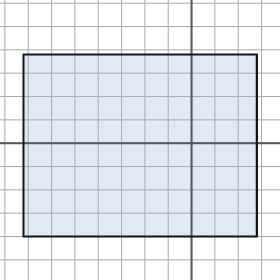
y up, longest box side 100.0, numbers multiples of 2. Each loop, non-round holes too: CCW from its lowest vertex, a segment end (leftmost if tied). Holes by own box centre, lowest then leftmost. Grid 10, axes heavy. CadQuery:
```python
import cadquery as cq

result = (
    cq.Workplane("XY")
    .moveTo(-72.0, -40.0)
    .lineTo(28.0, -40.0)
    .lineTo(28.0, 38.0)
    .lineTo(-72.0, 38.0)
    .close()
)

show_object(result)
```